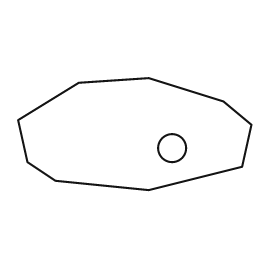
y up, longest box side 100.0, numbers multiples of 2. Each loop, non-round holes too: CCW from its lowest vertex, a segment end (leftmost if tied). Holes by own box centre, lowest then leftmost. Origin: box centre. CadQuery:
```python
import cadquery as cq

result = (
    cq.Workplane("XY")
    .moveTo(6.0, -24.0)
    .lineTo(46.0, -14.0)
    .lineTo(50.0, 4.0)
    .lineTo(38.0, 14.0)
    .lineTo(6.0, 24.0)
    .lineTo(-24.0, 22.0)
    .lineTo(-50.0, 6.0)
    .lineTo(-46.0, -12.0)
    .lineTo(-34.0, -20.0)
    .close()
    .moveTo(16.0, -6.0)
    .circle(6.0)
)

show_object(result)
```